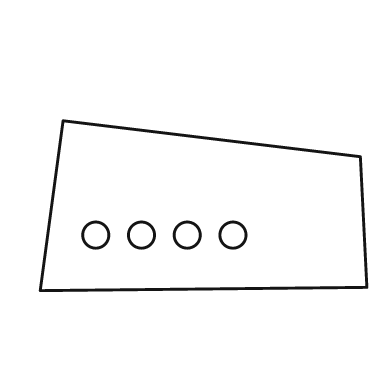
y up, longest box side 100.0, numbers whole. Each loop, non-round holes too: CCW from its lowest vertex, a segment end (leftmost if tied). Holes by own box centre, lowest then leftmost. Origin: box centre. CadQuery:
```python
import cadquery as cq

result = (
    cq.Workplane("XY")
    .moveTo(-50.0, -26.0)
    .lineTo(50.0, -25.0)
    .lineTo(48.0, 15.0)
    .lineTo(-43.0, 26.0)
    .close()
    .moveTo(-33.0, -9.0)
    .circle(4.0)
    .moveTo(-19.0, -9.0)
    .circle(4.0)
    .moveTo(-5.0, -9.0)
    .circle(4.0)
    .moveTo(9.0, -9.0)
    .circle(4.0)
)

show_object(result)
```